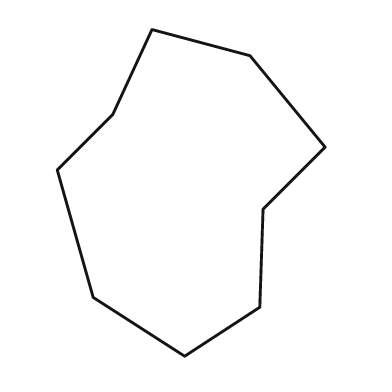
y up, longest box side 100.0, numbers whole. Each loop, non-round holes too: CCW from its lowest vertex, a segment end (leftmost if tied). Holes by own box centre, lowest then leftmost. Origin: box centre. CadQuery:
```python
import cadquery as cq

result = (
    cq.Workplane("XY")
    .moveTo(-2.0, -50.0)
    .lineTo(21.0, -35.0)
    .lineTo(22.0, -5.0)
    .lineTo(41.0, 14.0)
    .lineTo(18.0, 42.0)
    .lineTo(-12.0, 50.0)
    .lineTo(-24.0, 24.0)
    .lineTo(-41.0, 7.0)
    .lineTo(-30.0, -32.0)
    .close()
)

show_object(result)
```